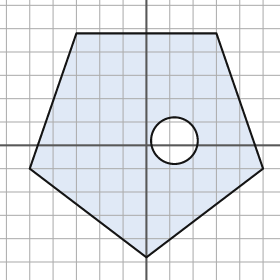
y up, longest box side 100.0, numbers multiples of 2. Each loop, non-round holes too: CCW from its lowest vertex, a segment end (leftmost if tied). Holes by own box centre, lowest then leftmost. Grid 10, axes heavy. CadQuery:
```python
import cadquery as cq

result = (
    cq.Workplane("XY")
    .moveTo(0.0, -48.0)
    .lineTo(50.0, -10.0)
    .lineTo(30.0, 48.0)
    .lineTo(-30.0, 48.0)
    .lineTo(-50.0, -10.0)
    .close()
    .moveTo(12.0, 2.0)
    .circle(10.0)
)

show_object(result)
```